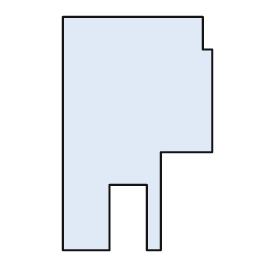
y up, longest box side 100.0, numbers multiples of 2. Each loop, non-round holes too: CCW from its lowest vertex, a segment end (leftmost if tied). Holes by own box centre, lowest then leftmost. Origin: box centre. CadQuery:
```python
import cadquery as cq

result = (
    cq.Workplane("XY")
    .moveTo(-32.0, -50.0)
    .lineTo(-12.0, -50.0)
    .lineTo(-12.0, -22.0)
    .lineTo(4.0, -22.0)
    .lineTo(4.0, -50.0)
    .lineTo(10.0, -50.0)
    .lineTo(10.0, -8.0)
    .lineTo(32.0, -8.0)
    .lineTo(32.0, 36.0)
    .lineTo(28.0, 36.0)
    .lineTo(28.0, 50.0)
    .lineTo(-32.0, 50.0)
    .close()
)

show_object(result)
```